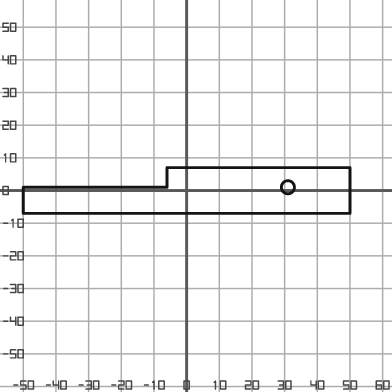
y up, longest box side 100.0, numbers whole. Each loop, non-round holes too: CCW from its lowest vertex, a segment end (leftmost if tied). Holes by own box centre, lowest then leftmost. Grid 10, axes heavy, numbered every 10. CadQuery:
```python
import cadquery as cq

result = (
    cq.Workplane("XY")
    .moveTo(-50.0, -7.0)
    .lineTo(50.0, -7.0)
    .lineTo(50.0, 7.0)
    .lineTo(-6.0, 7.0)
    .lineTo(-6.0, 1.0)
    .lineTo(-50.0, 1.0)
    .close()
    .moveTo(31.0, 1.0)
    .circle(2.0)
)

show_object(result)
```